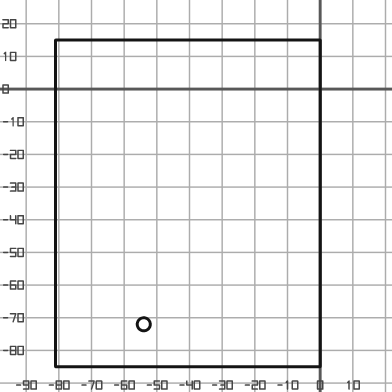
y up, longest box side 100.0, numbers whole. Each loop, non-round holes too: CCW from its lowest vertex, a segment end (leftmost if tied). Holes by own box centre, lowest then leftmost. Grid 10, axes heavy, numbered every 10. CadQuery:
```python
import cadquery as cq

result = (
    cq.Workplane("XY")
    .moveTo(-81.0, -85.0)
    .lineTo(0.0, -85.0)
    .lineTo(0.0, 15.0)
    .lineTo(-81.0, 15.0)
    .close()
    .moveTo(-54.0, -72.0)
    .circle(2.0)
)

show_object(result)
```